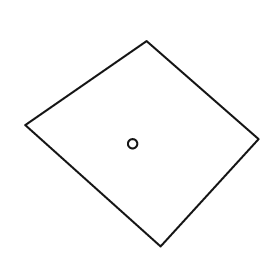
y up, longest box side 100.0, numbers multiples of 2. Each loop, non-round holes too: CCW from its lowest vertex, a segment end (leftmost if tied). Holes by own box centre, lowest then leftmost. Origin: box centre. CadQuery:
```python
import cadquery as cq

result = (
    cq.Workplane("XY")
    .moveTo(8.0, -44.0)
    .lineTo(50.0, 2.0)
    .lineTo(2.0, 44.0)
    .lineTo(-50.0, 8.0)
    .close()
    .moveTo(-4.0, 0.0)
    .circle(2.0)
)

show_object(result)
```